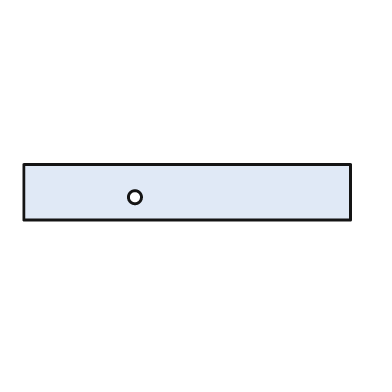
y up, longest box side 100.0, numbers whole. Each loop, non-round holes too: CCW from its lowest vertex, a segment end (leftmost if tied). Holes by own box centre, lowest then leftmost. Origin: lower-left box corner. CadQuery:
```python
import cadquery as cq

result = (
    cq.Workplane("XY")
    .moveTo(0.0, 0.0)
    .lineTo(100.0, 0.0)
    .lineTo(100.0, 17.0)
    .lineTo(0.0, 17.0)
    .close()
    .moveTo(34.0, 7.0)
    .circle(2.0)
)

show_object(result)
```